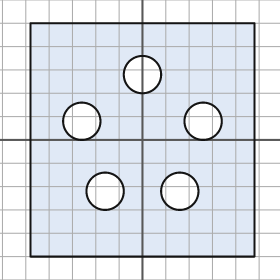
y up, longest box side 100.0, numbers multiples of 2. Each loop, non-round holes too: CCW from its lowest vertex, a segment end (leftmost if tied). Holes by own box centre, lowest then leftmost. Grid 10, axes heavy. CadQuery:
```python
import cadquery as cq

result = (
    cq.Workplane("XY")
    .moveTo(-48.0, -50.0)
    .lineTo(48.0, -50.0)
    .lineTo(48.0, 50.0)
    .lineTo(-48.0, 50.0)
    .close()
    .moveTo(-16.0, -22.0)
    .circle(8.0)
    .moveTo(16.0, -22.0)
    .circle(8.0)
    .moveTo(-26.0, 8.0)
    .circle(8.0)
    .moveTo(26.0, 8.0)
    .circle(8.0)
    .moveTo(0.0, 28.0)
    .circle(8.0)
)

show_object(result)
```